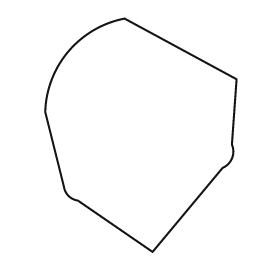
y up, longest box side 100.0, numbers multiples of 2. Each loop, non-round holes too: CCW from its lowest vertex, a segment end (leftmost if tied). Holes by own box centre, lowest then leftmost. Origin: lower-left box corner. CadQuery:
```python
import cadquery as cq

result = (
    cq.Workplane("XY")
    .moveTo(46.0, 0.0)
    .lineTo(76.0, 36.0)
    .threePointArc((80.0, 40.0), (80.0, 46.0))
    .lineTo(82.0, 74.0)
    .lineTo(34.0, 100.0)
    .threePointArc((10.0, 86.0), (0.0, 60.0))
    .lineTo(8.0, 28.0)
    .threePointArc((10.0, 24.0), (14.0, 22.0))
    .close()
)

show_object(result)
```